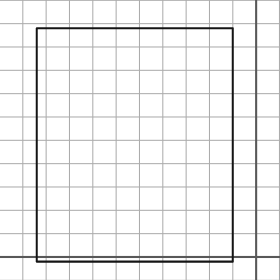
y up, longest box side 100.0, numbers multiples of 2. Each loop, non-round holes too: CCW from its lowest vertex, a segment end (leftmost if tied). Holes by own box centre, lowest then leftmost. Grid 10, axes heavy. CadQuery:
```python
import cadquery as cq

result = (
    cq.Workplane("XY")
    .moveTo(-94.0, -2.0)
    .lineTo(-10.0, -2.0)
    .lineTo(-10.0, 98.0)
    .lineTo(-94.0, 98.0)
    .close()
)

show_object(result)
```